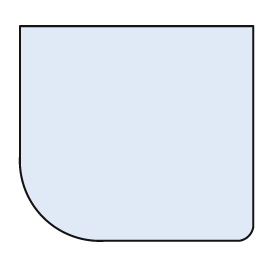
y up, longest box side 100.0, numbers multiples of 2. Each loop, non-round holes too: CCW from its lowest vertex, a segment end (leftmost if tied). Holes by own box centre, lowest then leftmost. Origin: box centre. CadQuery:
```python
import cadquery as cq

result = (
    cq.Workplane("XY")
    .moveTo(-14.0, -46.0)
    .lineTo(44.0, -46.0)
    .threePointArc((48.0, -44.0), (50.0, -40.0))
    .lineTo(50.0, 46.0)
    .lineTo(-50.0, 46.0)
    .lineTo(-50.0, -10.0)
    .threePointArc((-40.0, -36.0), (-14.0, -46.0))
    .close()
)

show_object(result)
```